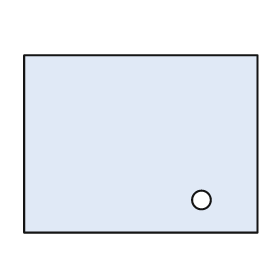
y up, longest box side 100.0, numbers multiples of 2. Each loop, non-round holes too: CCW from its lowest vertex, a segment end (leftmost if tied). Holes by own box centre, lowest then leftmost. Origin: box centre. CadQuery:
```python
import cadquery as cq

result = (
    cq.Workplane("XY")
    .moveTo(-50.0, -38.0)
    .lineTo(50.0, -38.0)
    .lineTo(50.0, 38.0)
    .lineTo(-50.0, 38.0)
    .close()
    .moveTo(26.0, -24.0)
    .circle(4.0)
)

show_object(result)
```